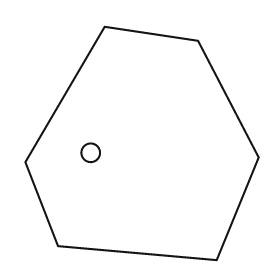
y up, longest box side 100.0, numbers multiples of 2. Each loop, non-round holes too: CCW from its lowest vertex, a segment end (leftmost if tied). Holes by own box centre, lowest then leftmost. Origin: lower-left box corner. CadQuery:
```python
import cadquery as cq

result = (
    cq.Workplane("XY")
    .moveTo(82.0, 0.0)
    .lineTo(100.0, 44.0)
    .lineTo(74.0, 94.0)
    .lineTo(34.0, 100.0)
    .lineTo(0.0, 42.0)
    .lineTo(14.0, 6.0)
    .close()
    .moveTo(28.0, 46.0)
    .circle(4.0)
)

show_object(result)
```